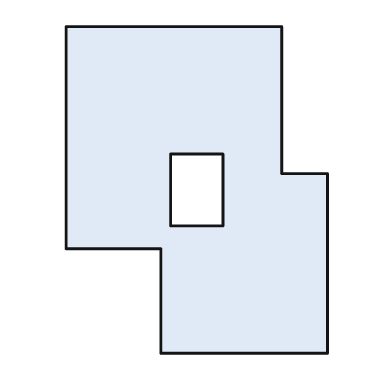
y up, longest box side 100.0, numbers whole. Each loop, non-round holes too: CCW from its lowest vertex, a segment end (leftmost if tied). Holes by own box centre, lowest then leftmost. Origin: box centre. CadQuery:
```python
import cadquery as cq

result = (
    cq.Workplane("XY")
    .moveTo(-11.0, -50.0)
    .lineTo(40.0, -50.0)
    .lineTo(40.0, 5.0)
    .lineTo(26.0, 5.0)
    .lineTo(26.0, 50.0)
    .lineTo(-40.0, 50.0)
    .lineTo(-40.0, -18.0)
    .lineTo(-11.0, -18.0)
    .close()
    .moveTo(-8.0, -11.0)
    .lineTo(8.0, -11.0)
    .lineTo(8.0, 11.0)
    .lineTo(-8.0, 11.0)
    .close()
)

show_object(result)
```